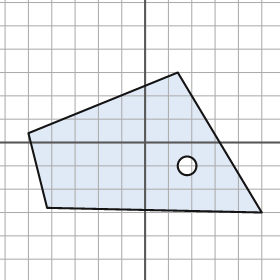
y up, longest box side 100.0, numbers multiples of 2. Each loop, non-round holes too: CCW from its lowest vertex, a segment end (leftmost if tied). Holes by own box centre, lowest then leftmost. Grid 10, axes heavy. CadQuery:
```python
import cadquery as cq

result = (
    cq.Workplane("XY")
    .moveTo(50.0, -30.0)
    .lineTo(14.0, 30.0)
    .lineTo(-50.0, 4.0)
    .lineTo(-42.0, -28.0)
    .close()
    .moveTo(18.0, -10.0)
    .circle(4.0)
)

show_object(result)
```